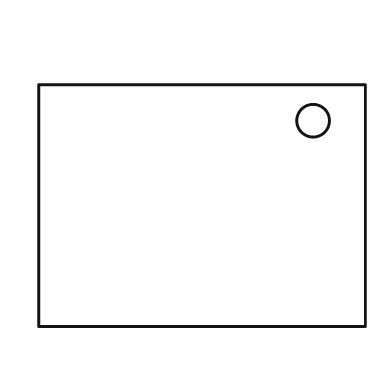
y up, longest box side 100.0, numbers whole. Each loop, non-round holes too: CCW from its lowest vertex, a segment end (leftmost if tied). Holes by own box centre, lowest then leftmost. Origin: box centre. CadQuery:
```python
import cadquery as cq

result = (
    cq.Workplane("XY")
    .moveTo(-50.0, -37.0)
    .lineTo(50.0, -37.0)
    .lineTo(50.0, 37.0)
    .lineTo(-50.0, 37.0)
    .close()
    .moveTo(34.0, 26.0)
    .circle(5.0)
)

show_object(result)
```